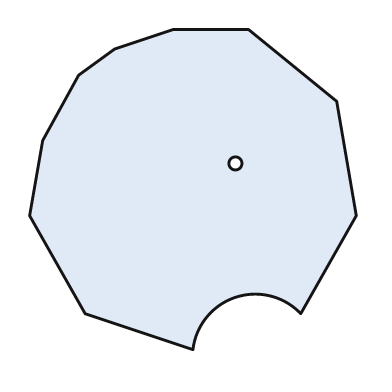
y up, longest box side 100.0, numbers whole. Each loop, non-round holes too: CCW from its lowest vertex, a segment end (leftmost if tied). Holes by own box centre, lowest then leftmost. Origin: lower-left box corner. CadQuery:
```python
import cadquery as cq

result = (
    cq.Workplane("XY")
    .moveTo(50.0, 0.0)
    .threePointArc((63.0, 16.0), (83.0, 11.0))
    .lineTo(100.0, 41.0)
    .lineTo(94.0, 76.0)
    .lineTo(67.0, 98.0)
    .lineTo(44.0, 98.0)
    .lineTo(26.0, 92.0)
    .lineTo(15.0, 84.0)
    .lineTo(4.0, 64.0)
    .lineTo(0.0, 41.0)
    .lineTo(17.0, 11.0)
    .close()
    .moveTo(63.0, 57.0)
    .circle(2.0)
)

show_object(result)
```